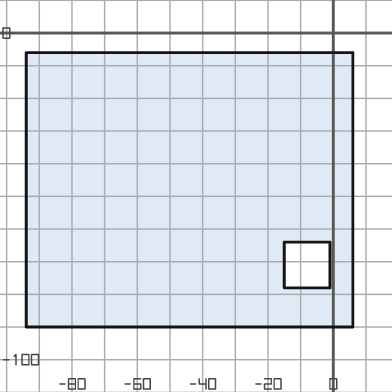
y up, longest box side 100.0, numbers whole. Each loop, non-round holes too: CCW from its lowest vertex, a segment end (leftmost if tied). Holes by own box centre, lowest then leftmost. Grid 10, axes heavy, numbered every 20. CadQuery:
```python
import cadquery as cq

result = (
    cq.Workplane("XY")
    .moveTo(-94.0, -90.0)
    .lineTo(6.0, -90.0)
    .lineTo(6.0, -6.0)
    .lineTo(-94.0, -6.0)
    .close()
    .moveTo(-15.0, -78.0)
    .lineTo(-1.0, -78.0)
    .lineTo(-1.0, -64.0)
    .lineTo(-15.0, -64.0)
    .close()
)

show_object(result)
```